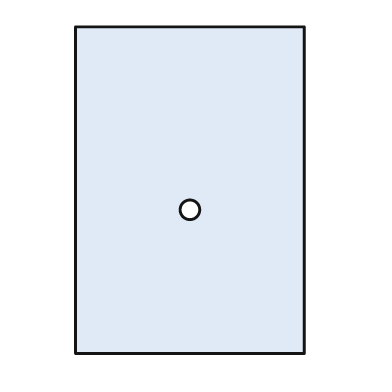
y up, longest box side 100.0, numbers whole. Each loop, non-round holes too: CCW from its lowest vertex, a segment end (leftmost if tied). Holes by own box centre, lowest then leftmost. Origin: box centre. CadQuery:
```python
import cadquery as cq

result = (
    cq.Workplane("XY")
    .moveTo(-35.0, -50.0)
    .lineTo(35.0, -50.0)
    .lineTo(35.0, 50.0)
    .lineTo(-35.0, 50.0)
    .close()
    .moveTo(0.0, -6.0)
    .circle(3.0)
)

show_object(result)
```